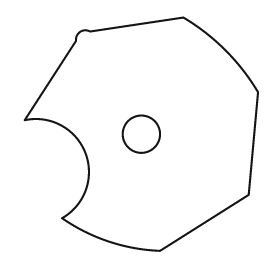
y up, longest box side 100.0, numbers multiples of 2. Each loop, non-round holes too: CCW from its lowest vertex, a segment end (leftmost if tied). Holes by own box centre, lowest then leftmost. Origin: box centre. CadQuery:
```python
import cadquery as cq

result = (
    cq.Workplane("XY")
    .moveTo(8.0, -50.0)
    .lineTo(46.0, -26.0)
    .lineTo(50.0, 18.0)
    .threePointArc((36.0, 36.0), (18.0, 50.0))
    .lineTo(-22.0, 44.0)
    .threePointArc((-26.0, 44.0), (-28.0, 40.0))
    .lineTo(-50.0, 6.0)
    .threePointArc((-24.0, -8.0), (-34.0, -36.0))
    .threePointArc((-14.0, -46.0), (8.0, -50.0))
    .close()
    .moveTo(0.0, 0.0)
    .circle(8.0)
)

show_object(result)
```